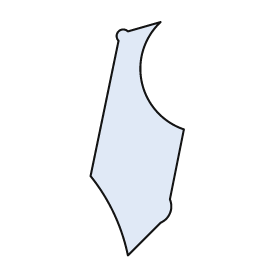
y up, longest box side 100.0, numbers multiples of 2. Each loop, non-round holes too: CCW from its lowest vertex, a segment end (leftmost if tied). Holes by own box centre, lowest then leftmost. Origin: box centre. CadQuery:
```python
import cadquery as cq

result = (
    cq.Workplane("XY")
    .moveTo(-4.0, -50.0)
    .lineTo(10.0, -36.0)
    .threePointArc((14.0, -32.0), (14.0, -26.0))
    .lineTo(20.0, 4.0)
    .threePointArc((2.0, 24.0), (10.0, 50.0))
    .lineTo(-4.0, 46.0)
    .threePointArc((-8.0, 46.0), (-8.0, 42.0))
    .lineTo(-20.0, -16.0)
    .threePointArc((-10.0, -32.0), (-4.0, -50.0))
    .close()
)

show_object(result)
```